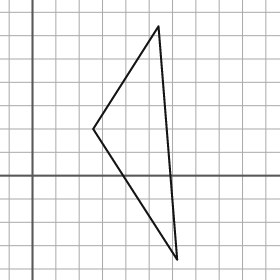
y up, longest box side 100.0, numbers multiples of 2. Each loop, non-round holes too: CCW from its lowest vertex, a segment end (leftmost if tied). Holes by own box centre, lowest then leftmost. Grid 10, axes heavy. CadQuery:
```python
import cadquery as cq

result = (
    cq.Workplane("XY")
    .moveTo(62.0, -36.0)
    .lineTo(54.0, 64.0)
    .lineTo(26.0, 20.0)
    .close()
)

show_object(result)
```